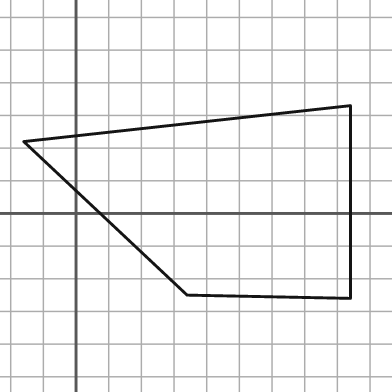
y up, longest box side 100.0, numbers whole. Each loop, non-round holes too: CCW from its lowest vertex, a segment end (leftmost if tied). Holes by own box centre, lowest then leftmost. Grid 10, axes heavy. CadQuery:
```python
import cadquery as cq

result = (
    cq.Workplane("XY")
    .moveTo(84.0, -26.0)
    .lineTo(84.0, 33.0)
    .lineTo(-16.0, 22.0)
    .lineTo(34.0, -25.0)
    .close()
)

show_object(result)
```